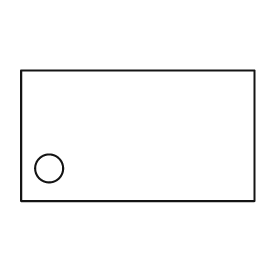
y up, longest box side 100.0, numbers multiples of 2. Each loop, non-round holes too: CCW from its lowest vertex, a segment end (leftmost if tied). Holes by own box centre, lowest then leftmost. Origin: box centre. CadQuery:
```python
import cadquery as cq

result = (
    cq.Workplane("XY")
    .moveTo(-50.0, -28.0)
    .lineTo(50.0, -28.0)
    .lineTo(50.0, 28.0)
    .lineTo(-50.0, 28.0)
    .close()
    .moveTo(-38.0, -14.0)
    .circle(6.0)
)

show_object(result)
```